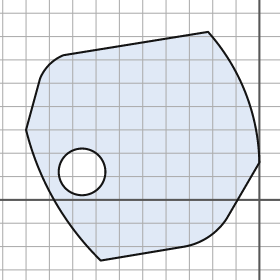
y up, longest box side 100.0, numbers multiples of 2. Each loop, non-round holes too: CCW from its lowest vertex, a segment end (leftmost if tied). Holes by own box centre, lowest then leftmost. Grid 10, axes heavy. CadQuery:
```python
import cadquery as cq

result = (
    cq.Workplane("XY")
    .moveTo(-68.0, -26.0)
    .lineTo(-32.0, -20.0)
    .threePointArc((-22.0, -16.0), (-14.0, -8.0))
    .lineTo(0.0, 16.0)
    .threePointArc((-6.0, 46.0), (-22.0, 72.0))
    .lineTo(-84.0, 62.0)
    .threePointArc((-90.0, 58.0), (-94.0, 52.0))
    .lineTo(-100.0, 30.0)
    .threePointArc((-88.0, 0.0), (-68.0, -26.0))
    .close()
    .moveTo(-76.0, 12.0)
    .circle(10.0)
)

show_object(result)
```